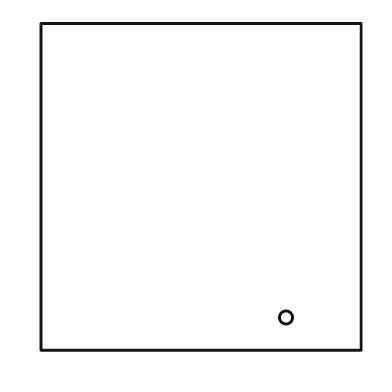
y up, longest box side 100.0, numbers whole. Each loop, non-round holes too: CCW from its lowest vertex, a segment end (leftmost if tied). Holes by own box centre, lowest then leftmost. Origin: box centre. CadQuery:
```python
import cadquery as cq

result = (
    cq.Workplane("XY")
    .moveTo(-49.0, -50.0)
    .lineTo(49.0, -50.0)
    .lineTo(49.0, 50.0)
    .lineTo(-49.0, 50.0)
    .close()
    .moveTo(26.0, -40.0)
    .circle(2.0)
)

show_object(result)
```